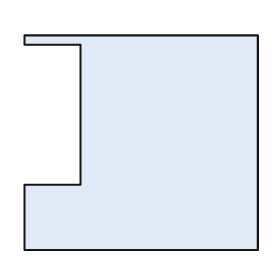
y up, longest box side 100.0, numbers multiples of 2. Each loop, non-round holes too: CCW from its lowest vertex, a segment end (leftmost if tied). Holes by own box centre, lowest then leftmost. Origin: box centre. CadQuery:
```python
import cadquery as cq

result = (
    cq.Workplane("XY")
    .moveTo(-50.0, -46.0)
    .lineTo(50.0, -46.0)
    .lineTo(50.0, 46.0)
    .lineTo(-50.0, 46.0)
    .lineTo(-50.0, 42.0)
    .lineTo(-26.0, 42.0)
    .lineTo(-26.0, -18.0)
    .lineTo(-50.0, -18.0)
    .close()
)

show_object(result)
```